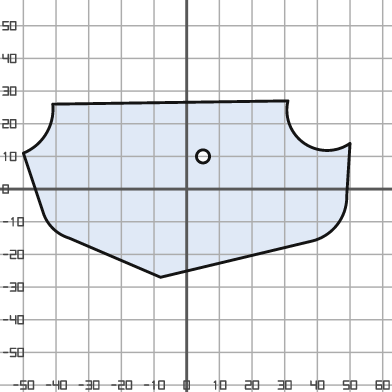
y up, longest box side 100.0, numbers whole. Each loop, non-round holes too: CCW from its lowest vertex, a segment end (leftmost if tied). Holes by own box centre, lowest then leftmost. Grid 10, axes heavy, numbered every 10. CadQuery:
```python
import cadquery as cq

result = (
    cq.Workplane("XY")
    .moveTo(-8.0, -27.0)
    .lineTo(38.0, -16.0)
    .threePointArc((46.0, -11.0), (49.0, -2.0))
    .lineTo(50.0, 14.0)
    .threePointArc((36.0, 14.0), (31.0, 27.0))
    .lineTo(-41.0, 26.0)
    .threePointArc((-43.0, 17.0), (-50.0, 11.0))
    .lineTo(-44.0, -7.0)
    .threePointArc((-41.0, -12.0), (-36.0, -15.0))
    .close()
    .moveTo(5.0, 10.0)
    .circle(2.0)
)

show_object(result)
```